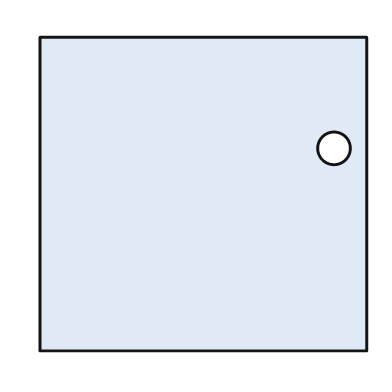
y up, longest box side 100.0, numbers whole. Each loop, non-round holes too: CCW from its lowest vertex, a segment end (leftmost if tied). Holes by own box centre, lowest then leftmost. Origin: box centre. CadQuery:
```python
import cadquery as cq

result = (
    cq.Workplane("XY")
    .moveTo(-50.0, -48.0)
    .lineTo(50.0, -48.0)
    .lineTo(50.0, 48.0)
    .lineTo(-50.0, 48.0)
    .close()
    .moveTo(40.0, 14.0)
    .circle(5.0)
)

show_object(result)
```